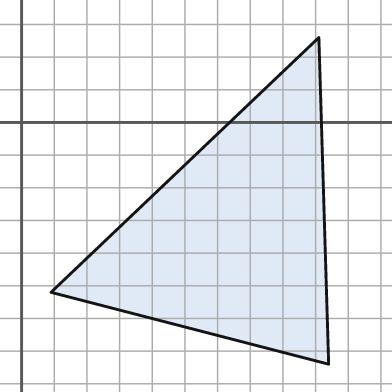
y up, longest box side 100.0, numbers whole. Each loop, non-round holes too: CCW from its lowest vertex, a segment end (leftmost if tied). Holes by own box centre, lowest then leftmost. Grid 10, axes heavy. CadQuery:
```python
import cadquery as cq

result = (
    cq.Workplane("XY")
    .moveTo(94.0, -74.0)
    .lineTo(91.0, 26.0)
    .lineTo(9.0, -52.0)
    .close()
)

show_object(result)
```